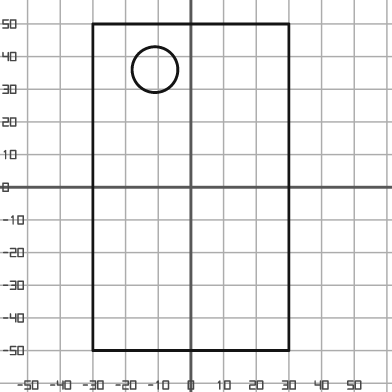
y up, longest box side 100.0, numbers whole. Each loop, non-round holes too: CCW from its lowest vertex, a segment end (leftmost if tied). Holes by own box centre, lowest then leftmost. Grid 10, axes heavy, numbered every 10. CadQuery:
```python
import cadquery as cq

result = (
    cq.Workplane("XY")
    .moveTo(-30.0, -50.0)
    .lineTo(30.0, -50.0)
    .lineTo(30.0, 50.0)
    .lineTo(-30.0, 50.0)
    .close()
    .moveTo(-11.0, 36.0)
    .circle(7.0)
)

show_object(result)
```